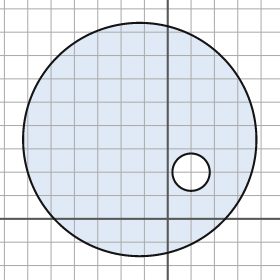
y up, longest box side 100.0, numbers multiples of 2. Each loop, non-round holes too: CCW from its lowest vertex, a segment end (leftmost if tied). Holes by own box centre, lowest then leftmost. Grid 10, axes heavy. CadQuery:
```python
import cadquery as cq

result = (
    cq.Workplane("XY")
    .moveTo(-12.0, 34.0)
    .circle(50.0)
    .moveTo(10.0, 20.0)
    .circle(8.0)
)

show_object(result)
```